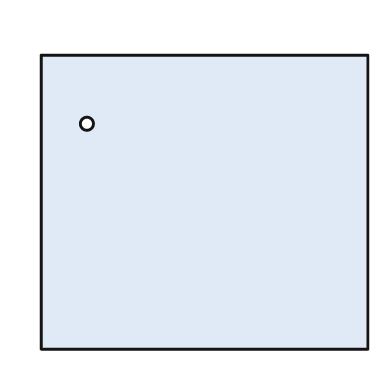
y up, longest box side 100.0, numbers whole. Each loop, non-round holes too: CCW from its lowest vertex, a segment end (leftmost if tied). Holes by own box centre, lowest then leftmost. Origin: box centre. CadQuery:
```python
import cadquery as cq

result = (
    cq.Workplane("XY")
    .moveTo(-50.0, -45.0)
    .lineTo(50.0, -45.0)
    .lineTo(50.0, 45.0)
    .lineTo(-50.0, 45.0)
    .close()
    .moveTo(-36.0, 24.0)
    .circle(2.0)
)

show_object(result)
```